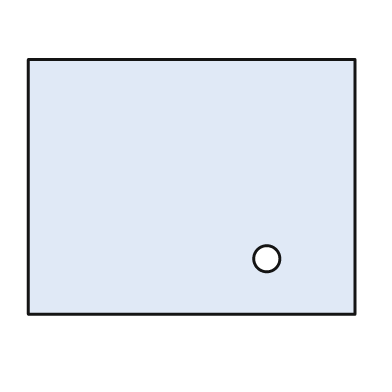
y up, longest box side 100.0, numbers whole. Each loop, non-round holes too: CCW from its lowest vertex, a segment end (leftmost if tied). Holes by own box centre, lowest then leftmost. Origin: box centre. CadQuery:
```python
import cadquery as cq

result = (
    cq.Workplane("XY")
    .moveTo(-50.0, -39.0)
    .lineTo(50.0, -39.0)
    .lineTo(50.0, 39.0)
    .lineTo(-50.0, 39.0)
    .close()
    .moveTo(23.0, -22.0)
    .circle(4.0)
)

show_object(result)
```